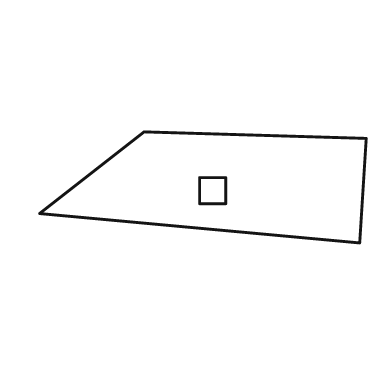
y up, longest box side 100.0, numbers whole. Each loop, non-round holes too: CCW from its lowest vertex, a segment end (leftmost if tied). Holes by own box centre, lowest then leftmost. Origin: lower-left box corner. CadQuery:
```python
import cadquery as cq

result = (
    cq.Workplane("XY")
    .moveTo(98.0, 0.0)
    .lineTo(100.0, 32.0)
    .lineTo(32.0, 34.0)
    .lineTo(0.0, 9.0)
    .close()
    .moveTo(49.0, 12.0)
    .lineTo(57.0, 12.0)
    .lineTo(57.0, 20.0)
    .lineTo(49.0, 20.0)
    .close()
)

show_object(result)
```